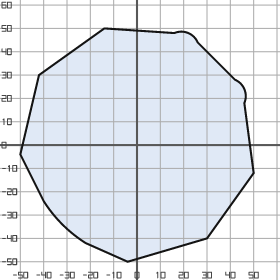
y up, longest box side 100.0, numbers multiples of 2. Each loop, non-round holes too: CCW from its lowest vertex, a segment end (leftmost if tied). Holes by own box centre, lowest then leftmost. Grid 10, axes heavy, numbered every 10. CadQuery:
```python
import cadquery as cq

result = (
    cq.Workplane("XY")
    .moveTo(-4.0, -50.0)
    .lineTo(30.0, -40.0)
    .lineTo(50.0, -12.0)
    .lineTo(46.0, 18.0)
    .threePointArc((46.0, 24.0), (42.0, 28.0))
    .lineTo(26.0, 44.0)
    .threePointArc((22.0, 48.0), (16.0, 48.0))
    .lineTo(-14.0, 50.0)
    .lineTo(-42.0, 30.0)
    .lineTo(-50.0, -4.0)
    .lineTo(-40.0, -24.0)
    .threePointArc((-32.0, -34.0), (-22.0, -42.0))
    .close()
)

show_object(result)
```